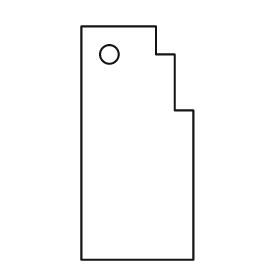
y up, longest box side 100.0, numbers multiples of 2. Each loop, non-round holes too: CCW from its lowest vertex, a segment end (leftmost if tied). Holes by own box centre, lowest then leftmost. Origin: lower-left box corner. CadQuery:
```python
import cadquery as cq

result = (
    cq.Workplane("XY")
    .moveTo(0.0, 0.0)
    .lineTo(48.0, 0.0)
    .lineTo(48.0, 64.0)
    .lineTo(40.0, 64.0)
    .lineTo(40.0, 88.0)
    .lineTo(32.0, 88.0)
    .lineTo(32.0, 100.0)
    .lineTo(0.0, 100.0)
    .close()
    .moveTo(12.0, 88.0)
    .circle(4.0)
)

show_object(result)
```